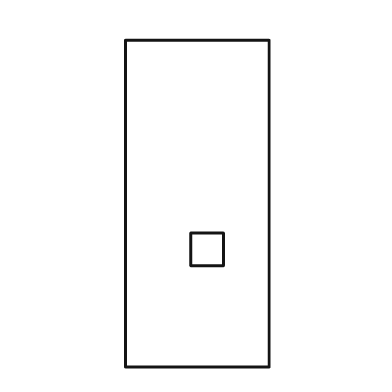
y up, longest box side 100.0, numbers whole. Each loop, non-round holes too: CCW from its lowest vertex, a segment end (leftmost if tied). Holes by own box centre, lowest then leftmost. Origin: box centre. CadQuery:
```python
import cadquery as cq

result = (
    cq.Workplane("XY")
    .moveTo(-22.0, -50.0)
    .lineTo(22.0, -50.0)
    .lineTo(22.0, 50.0)
    .lineTo(-22.0, 50.0)
    .close()
    .moveTo(-2.0, -19.0)
    .lineTo(8.0, -19.0)
    .lineTo(8.0, -9.0)
    .lineTo(-2.0, -9.0)
    .close()
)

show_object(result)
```